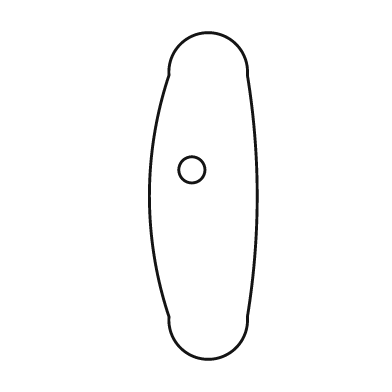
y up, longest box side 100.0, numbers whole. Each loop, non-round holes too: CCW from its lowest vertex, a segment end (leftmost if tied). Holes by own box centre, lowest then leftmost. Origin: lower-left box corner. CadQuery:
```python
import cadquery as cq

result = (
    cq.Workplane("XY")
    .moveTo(6.0, 13.0)
    .threePointArc((18.0, 0.0), (30.0, 13.0))
    .threePointArc((33.0, 50.0), (30.0, 87.0))
    .threePointArc((18.0, 100.0), (6.0, 87.0))
    .threePointArc((0.0, 50.0), (6.0, 13.0))
    .close()
    .moveTo(13.0, 58.0)
    .circle(4.0)
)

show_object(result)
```